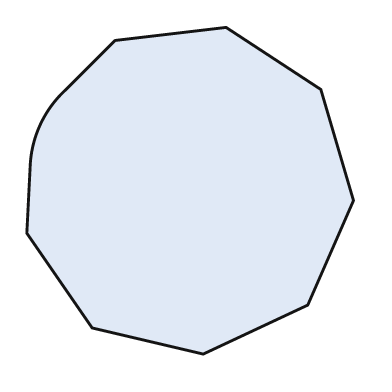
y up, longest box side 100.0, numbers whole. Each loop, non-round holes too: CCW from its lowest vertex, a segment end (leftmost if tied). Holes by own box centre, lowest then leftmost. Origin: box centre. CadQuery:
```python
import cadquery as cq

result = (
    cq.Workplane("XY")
    .moveTo(4.0, -50.0)
    .lineTo(36.0, -35.0)
    .lineTo(50.0, -3.0)
    .lineTo(40.0, 31.0)
    .lineTo(11.0, 50.0)
    .lineTo(-23.0, 46.0)
    .lineTo(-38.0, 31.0)
    .threePointArc((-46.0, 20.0), (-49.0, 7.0))
    .lineTo(-50.0, -13.0)
    .lineTo(-30.0, -42.0)
    .close()
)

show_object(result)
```